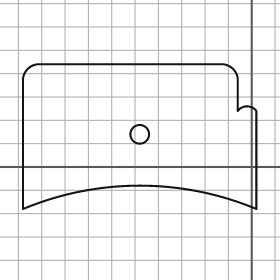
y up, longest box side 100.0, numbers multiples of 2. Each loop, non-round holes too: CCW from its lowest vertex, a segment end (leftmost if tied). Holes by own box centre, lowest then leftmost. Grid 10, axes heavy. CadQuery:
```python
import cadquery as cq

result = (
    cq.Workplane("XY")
    .moveTo(-98.0, -18.0)
    .threePointArc((-48.0, -8.0), (2.0, -18.0))
    .lineTo(2.0, 24.0)
    .threePointArc((-2.0, 26.0), (-6.0, 24.0))
    .lineTo(-6.0, 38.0)
    .threePointArc((-8.0, 42.0), (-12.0, 44.0))
    .lineTo(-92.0, 44.0)
    .threePointArc((-96.0, 42.0), (-98.0, 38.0))
    .close()
    .moveTo(-48.0, 14.0)
    .circle(4.0)
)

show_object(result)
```